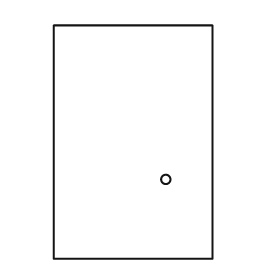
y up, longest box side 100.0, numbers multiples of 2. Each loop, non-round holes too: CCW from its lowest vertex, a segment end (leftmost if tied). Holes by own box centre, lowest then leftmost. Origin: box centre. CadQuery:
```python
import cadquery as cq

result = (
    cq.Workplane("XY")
    .moveTo(-34.0, -50.0)
    .lineTo(34.0, -50.0)
    .lineTo(34.0, 50.0)
    .lineTo(-34.0, 50.0)
    .close()
    .moveTo(14.0, -16.0)
    .circle(2.0)
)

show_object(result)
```